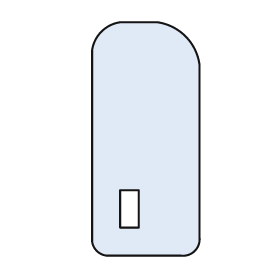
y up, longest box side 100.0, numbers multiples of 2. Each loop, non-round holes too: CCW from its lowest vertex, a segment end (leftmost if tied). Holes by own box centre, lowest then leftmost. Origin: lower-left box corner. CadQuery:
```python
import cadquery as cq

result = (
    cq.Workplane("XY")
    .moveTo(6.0, 0.0)
    .lineTo(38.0, 0.0)
    .threePointArc((44.0, 2.0), (46.0, 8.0))
    .lineTo(46.0, 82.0)
    .threePointArc((40.0, 94.0), (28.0, 100.0))
    .lineTo(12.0, 100.0)
    .threePointArc((4.0, 96.0), (0.0, 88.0))
    .lineTo(0.0, 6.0)
    .threePointArc((2.0, 2.0), (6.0, 0.0))
    .close()
    .moveTo(12.0, 12.0)
    .lineTo(20.0, 12.0)
    .lineTo(20.0, 28.0)
    .lineTo(12.0, 28.0)
    .close()
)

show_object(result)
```